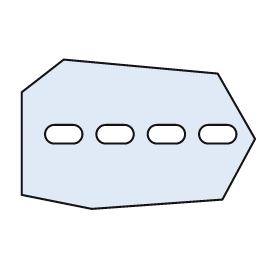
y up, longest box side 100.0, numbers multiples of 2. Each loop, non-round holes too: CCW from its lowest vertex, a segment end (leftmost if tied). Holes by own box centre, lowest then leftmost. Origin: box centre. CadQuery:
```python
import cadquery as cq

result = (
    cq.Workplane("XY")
    .moveTo(-20.0, -32.0)
    .lineTo(36.0, -28.0)
    .lineTo(50.0, -2.0)
    .lineTo(34.0, 26.0)
    .lineTo(-32.0, 32.0)
    .lineTo(-50.0, 18.0)
    .lineTo(-50.0, -26.0)
    .close()
    .moveTo(-36.0, -4.0)
    .lineTo(-28.0, -4.0)
    .threePointArc((-24.0, 0.0), (-28.0, 4.0))
    .lineTo(-36.0, 4.0)
    .threePointArc((-40.0, 0.0), (-36.0, -4.0))
    .close()
    .moveTo(-14.0, -4.0)
    .lineTo(-6.0, -4.0)
    .threePointArc((-2.0, 0.0), (-6.0, 4.0))
    .lineTo(-14.0, 4.0)
    .threePointArc((-18.0, 0.0), (-14.0, -4.0))
    .close()
    .moveTo(8.0, -4.0)
    .lineTo(16.0, -4.0)
    .threePointArc((20.0, 0.0), (16.0, 4.0))
    .lineTo(8.0, 4.0)
    .threePointArc((4.0, 0.0), (8.0, -4.0))
    .close()
    .moveTo(30.0, -4.0)
    .lineTo(38.0, -4.0)
    .threePointArc((42.0, 0.0), (38.0, 4.0))
    .lineTo(30.0, 4.0)
    .threePointArc((26.0, 0.0), (30.0, -4.0))
    .close()
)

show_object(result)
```